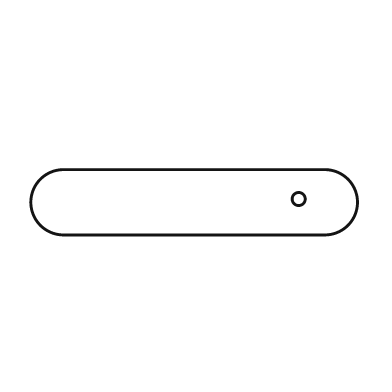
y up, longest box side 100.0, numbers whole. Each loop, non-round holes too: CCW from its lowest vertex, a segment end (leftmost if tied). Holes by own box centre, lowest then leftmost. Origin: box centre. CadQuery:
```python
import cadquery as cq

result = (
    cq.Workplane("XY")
    .moveTo(-40.0, -10.0)
    .lineTo(40.0, -10.0)
    .threePointArc((50.0, 0.0), (40.0, 10.0))
    .lineTo(-40.0, 10.0)
    .threePointArc((-50.0, 0.0), (-40.0, -10.0))
    .close()
    .moveTo(32.0, 1.0)
    .circle(2.0)
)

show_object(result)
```